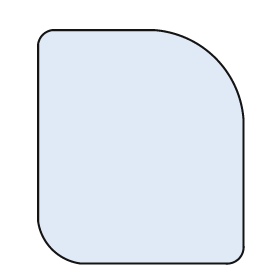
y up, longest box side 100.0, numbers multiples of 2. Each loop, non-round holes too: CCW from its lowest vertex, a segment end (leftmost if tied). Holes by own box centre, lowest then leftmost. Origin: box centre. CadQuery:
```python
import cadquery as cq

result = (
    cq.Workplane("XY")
    .moveTo(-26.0, -50.0)
    .lineTo(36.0, -50.0)
    .threePointArc((42.0, -48.0), (44.0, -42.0))
    .lineTo(44.0, 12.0)
    .threePointArc((32.0, 38.0), (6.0, 50.0))
    .lineTo(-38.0, 50.0)
    .threePointArc((-42.0, 48.0), (-44.0, 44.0))
    .lineTo(-44.0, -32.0)
    .threePointArc((-38.0, -44.0), (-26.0, -50.0))
    .close()
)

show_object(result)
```